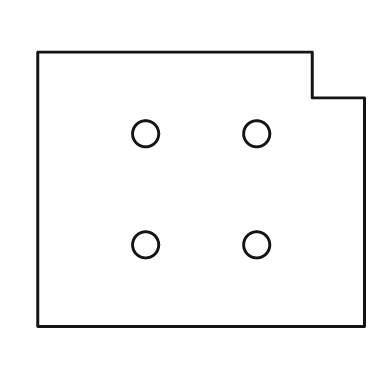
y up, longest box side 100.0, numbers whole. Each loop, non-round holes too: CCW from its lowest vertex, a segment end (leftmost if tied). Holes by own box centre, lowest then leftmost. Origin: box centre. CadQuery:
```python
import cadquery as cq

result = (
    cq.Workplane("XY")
    .moveTo(-50.0, -42.0)
    .lineTo(50.0, -42.0)
    .lineTo(50.0, 28.0)
    .lineTo(34.0, 28.0)
    .lineTo(34.0, 42.0)
    .lineTo(-50.0, 42.0)
    .close()
    .moveTo(-17.0, -17.0)
    .circle(4.0)
    .moveTo(17.0, -17.0)
    .circle(4.0)
    .moveTo(-17.0, 17.0)
    .circle(4.0)
    .moveTo(17.0, 17.0)
    .circle(4.0)
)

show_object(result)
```